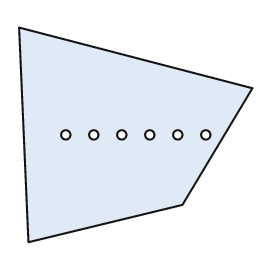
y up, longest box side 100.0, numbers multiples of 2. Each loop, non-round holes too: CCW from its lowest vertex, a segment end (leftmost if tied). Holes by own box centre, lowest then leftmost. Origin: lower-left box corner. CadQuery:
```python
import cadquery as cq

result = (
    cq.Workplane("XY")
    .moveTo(4.0, 0.0)
    .lineTo(70.0, 16.0)
    .lineTo(100.0, 66.0)
    .lineTo(0.0, 92.0)
    .close()
    .moveTo(20.0, 46.0)
    .circle(2.0)
    .moveTo(32.0, 46.0)
    .circle(2.0)
    .moveTo(44.0, 46.0)
    .circle(2.0)
    .moveTo(56.0, 46.0)
    .circle(2.0)
    .moveTo(68.0, 46.0)
    .circle(2.0)
    .moveTo(80.0, 46.0)
    .circle(2.0)
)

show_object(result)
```